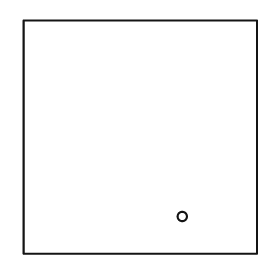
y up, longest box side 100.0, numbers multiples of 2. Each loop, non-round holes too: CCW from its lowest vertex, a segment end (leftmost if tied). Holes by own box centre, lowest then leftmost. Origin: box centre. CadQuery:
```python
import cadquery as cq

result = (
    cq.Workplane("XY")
    .moveTo(-50.0, -50.0)
    .lineTo(50.0, -50.0)
    .lineTo(50.0, 50.0)
    .lineTo(-50.0, 50.0)
    .close()
    .moveTo(18.0, -34.0)
    .circle(2.0)
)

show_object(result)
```